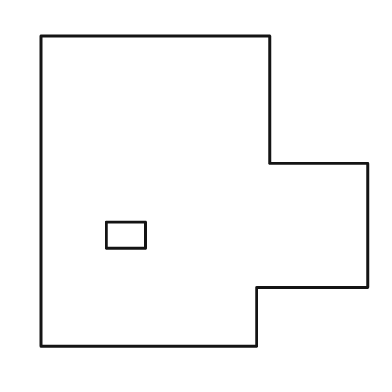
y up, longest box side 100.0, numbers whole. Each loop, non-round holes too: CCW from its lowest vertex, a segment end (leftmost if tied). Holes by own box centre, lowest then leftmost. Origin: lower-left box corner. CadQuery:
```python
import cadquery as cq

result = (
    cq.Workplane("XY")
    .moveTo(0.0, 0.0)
    .lineTo(66.0, 0.0)
    .lineTo(66.0, 18.0)
    .lineTo(100.0, 18.0)
    .lineTo(100.0, 56.0)
    .lineTo(70.0, 56.0)
    .lineTo(70.0, 95.0)
    .lineTo(0.0, 95.0)
    .close()
    .moveTo(20.0, 30.0)
    .lineTo(32.0, 30.0)
    .lineTo(32.0, 38.0)
    .lineTo(20.0, 38.0)
    .close()
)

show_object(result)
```